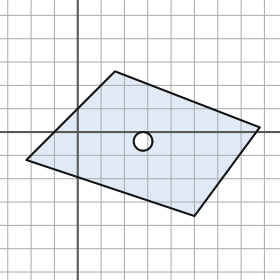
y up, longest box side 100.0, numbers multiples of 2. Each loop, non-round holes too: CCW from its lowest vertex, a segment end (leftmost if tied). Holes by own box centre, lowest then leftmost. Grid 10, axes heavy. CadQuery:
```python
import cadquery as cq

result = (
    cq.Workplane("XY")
    .moveTo(50.0, -36.0)
    .lineTo(78.0, 2.0)
    .lineTo(16.0, 26.0)
    .lineTo(-22.0, -12.0)
    .close()
    .moveTo(28.0, -4.0)
    .circle(4.0)
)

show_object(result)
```